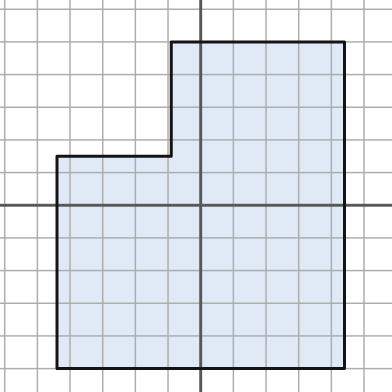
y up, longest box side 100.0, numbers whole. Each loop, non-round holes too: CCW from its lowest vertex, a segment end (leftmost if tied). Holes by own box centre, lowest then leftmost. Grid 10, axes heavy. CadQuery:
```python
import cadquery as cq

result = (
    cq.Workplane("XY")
    .moveTo(-44.0, -50.0)
    .lineTo(44.0, -50.0)
    .lineTo(44.0, 50.0)
    .lineTo(-9.0, 50.0)
    .lineTo(-9.0, 15.0)
    .lineTo(-44.0, 15.0)
    .close()
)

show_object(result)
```